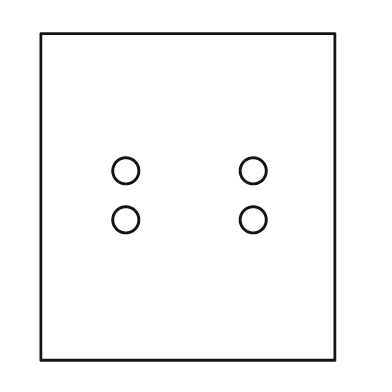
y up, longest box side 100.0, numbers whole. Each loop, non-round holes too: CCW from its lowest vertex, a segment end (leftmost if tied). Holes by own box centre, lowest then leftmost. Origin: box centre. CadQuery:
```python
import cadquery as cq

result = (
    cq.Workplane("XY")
    .moveTo(-45.0, -50.0)
    .lineTo(45.0, -50.0)
    .lineTo(45.0, 50.0)
    .lineTo(-45.0, 50.0)
    .close()
    .moveTo(-19.0, -7.0)
    .circle(4.0)
    .moveTo(20.0, -7.0)
    .circle(4.0)
    .moveTo(-19.0, 8.0)
    .circle(4.0)
    .moveTo(20.0, 8.0)
    .circle(4.0)
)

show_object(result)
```